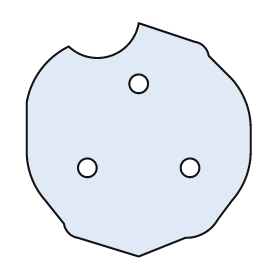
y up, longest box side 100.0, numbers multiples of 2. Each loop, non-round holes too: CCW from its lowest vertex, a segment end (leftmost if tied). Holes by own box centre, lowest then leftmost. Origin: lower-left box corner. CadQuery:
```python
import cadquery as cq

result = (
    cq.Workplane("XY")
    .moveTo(48.0, 0.0)
    .lineTo(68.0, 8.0)
    .threePointArc((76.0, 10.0), (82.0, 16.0))
    .lineTo(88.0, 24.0)
    .threePointArc((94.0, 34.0), (96.0, 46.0))
    .lineTo(96.0, 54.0)
    .threePointArc((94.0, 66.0), (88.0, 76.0))
    .lineTo(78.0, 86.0)
    .threePointArc((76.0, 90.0), (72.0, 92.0))
    .lineTo(48.0, 100.0)
    .threePointArc((36.0, 86.0), (18.0, 90.0))
    .threePointArc((6.0, 80.0), (0.0, 66.0))
    .lineTo(0.0, 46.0)
    .threePointArc((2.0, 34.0), (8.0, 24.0))
    .lineTo(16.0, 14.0)
    .threePointArc((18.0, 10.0), (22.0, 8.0))
    .close()
    .moveTo(26.0, 38.0)
    .circle(4.0)
    .moveTo(70.0, 38.0)
    .circle(4.0)
    .moveTo(48.0, 74.0)
    .circle(4.0)
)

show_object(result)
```